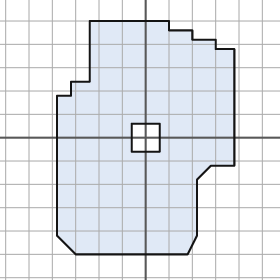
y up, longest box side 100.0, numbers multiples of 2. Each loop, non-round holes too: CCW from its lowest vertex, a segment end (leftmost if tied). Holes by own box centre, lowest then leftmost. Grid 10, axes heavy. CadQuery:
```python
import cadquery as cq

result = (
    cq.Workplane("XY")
    .moveTo(-30.0, -50.0)
    .lineTo(18.0, -50.0)
    .lineTo(22.0, -42.0)
    .lineTo(22.0, -18.0)
    .lineTo(28.0, -12.0)
    .lineTo(38.0, -12.0)
    .lineTo(38.0, 38.0)
    .lineTo(30.0, 38.0)
    .lineTo(30.0, 42.0)
    .lineTo(20.0, 42.0)
    .lineTo(20.0, 46.0)
    .lineTo(10.0, 46.0)
    .lineTo(10.0, 50.0)
    .lineTo(-24.0, 50.0)
    .lineTo(-24.0, 24.0)
    .lineTo(-32.0, 24.0)
    .lineTo(-32.0, 18.0)
    .lineTo(-38.0, 18.0)
    .lineTo(-38.0, -42.0)
    .close()
    .moveTo(-6.0, -6.0)
    .lineTo(6.0, -6.0)
    .lineTo(6.0, 6.0)
    .lineTo(-6.0, 6.0)
    .close()
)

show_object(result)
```